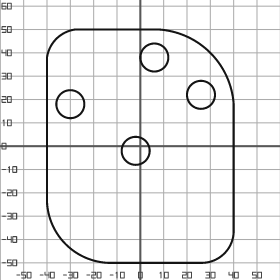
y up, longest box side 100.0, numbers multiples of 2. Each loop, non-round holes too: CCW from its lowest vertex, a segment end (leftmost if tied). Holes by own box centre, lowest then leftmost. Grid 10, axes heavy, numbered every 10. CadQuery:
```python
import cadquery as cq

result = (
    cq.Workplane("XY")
    .moveTo(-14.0, -50.0)
    .lineTo(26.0, -50.0)
    .threePointArc((36.0, -46.0), (40.0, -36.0))
    .lineTo(40.0, 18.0)
    .threePointArc((30.0, 40.0), (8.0, 50.0))
    .lineTo(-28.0, 50.0)
    .threePointArc((-36.0, 46.0), (-40.0, 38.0))
    .lineTo(-40.0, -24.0)
    .threePointArc((-32.0, -42.0), (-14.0, -50.0))
    .close()
    .moveTo(-2.0, -2.0)
    .circle(6.0)
    .moveTo(-30.0, 18.0)
    .circle(6.0)
    .moveTo(26.0, 22.0)
    .circle(6.0)
    .moveTo(6.0, 38.0)
    .circle(6.0)
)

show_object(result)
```